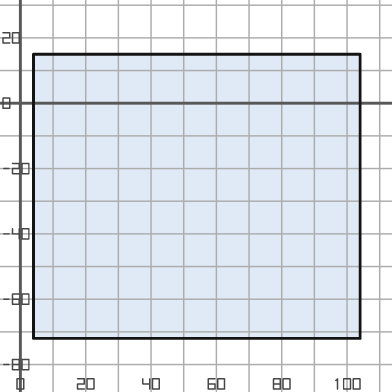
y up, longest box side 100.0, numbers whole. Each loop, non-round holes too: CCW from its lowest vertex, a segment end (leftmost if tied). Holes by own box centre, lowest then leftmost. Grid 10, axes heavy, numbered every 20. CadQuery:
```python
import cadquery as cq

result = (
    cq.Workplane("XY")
    .moveTo(4.0, -72.0)
    .lineTo(104.0, -72.0)
    .lineTo(104.0, 15.0)
    .lineTo(4.0, 15.0)
    .close()
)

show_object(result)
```